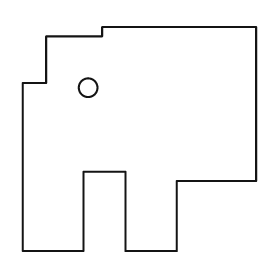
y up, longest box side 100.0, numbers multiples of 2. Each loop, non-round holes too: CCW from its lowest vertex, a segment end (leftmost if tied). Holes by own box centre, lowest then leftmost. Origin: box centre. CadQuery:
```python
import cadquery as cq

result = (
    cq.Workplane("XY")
    .moveTo(-50.0, -48.0)
    .lineTo(-24.0, -48.0)
    .lineTo(-24.0, -14.0)
    .lineTo(-6.0, -14.0)
    .lineTo(-6.0, -48.0)
    .lineTo(16.0, -48.0)
    .lineTo(16.0, -18.0)
    .lineTo(50.0, -18.0)
    .lineTo(50.0, 48.0)
    .lineTo(-16.0, 48.0)
    .lineTo(-16.0, 44.0)
    .lineTo(-40.0, 44.0)
    .lineTo(-40.0, 24.0)
    .lineTo(-50.0, 24.0)
    .close()
    .moveTo(-22.0, 22.0)
    .circle(4.0)
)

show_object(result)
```